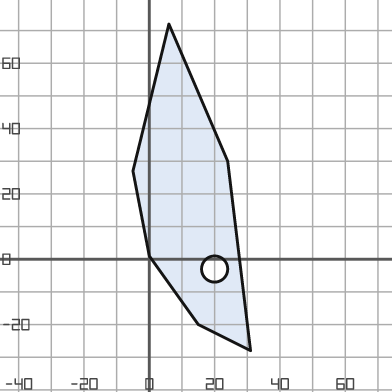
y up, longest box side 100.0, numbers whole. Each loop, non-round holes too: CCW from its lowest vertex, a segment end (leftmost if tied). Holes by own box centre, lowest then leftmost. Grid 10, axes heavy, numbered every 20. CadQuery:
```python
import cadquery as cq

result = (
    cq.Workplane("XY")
    .moveTo(31.0, -28.0)
    .lineTo(24.0, 30.0)
    .lineTo(6.0, 72.0)
    .lineTo(-5.0, 27.0)
    .lineTo(0.0, 1.0)
    .lineTo(15.0, -20.0)
    .close()
    .moveTo(20.0, -3.0)
    .circle(4.0)
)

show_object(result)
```